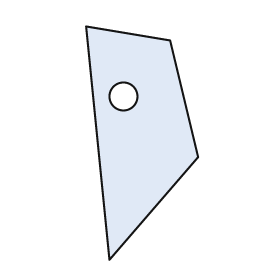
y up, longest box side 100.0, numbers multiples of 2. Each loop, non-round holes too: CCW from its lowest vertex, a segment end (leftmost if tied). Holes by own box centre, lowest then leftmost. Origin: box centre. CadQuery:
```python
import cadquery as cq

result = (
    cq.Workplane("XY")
    .moveTo(-14.0, -50.0)
    .lineTo(24.0, -6.0)
    .lineTo(12.0, 44.0)
    .lineTo(-24.0, 50.0)
    .close()
    .moveTo(-8.0, 20.0)
    .circle(6.0)
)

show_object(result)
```